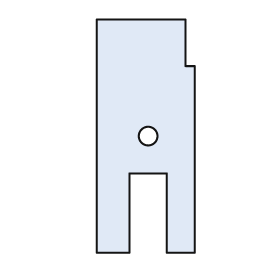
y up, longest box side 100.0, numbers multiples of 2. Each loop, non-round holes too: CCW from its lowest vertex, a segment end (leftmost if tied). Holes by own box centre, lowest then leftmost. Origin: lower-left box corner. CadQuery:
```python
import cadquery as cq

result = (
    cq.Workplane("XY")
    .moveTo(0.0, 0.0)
    .lineTo(14.0, 0.0)
    .lineTo(14.0, 34.0)
    .lineTo(30.0, 34.0)
    .lineTo(30.0, 0.0)
    .lineTo(42.0, 0.0)
    .lineTo(42.0, 80.0)
    .lineTo(38.0, 80.0)
    .lineTo(38.0, 100.0)
    .lineTo(0.0, 100.0)
    .close()
    .moveTo(22.0, 50.0)
    .circle(4.0)
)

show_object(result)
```